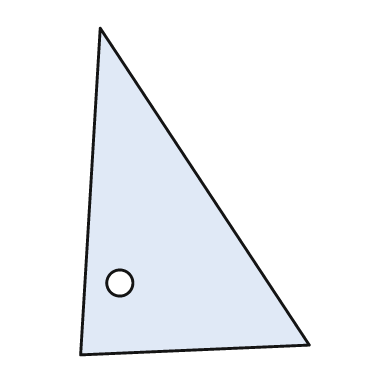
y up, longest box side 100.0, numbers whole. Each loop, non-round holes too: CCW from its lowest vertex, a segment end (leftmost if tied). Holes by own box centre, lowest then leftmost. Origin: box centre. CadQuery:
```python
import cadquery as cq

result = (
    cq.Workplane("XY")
    .moveTo(-35.0, -50.0)
    .lineTo(35.0, -47.0)
    .lineTo(-29.0, 50.0)
    .close()
    .moveTo(-23.0, -28.0)
    .circle(4.0)
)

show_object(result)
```